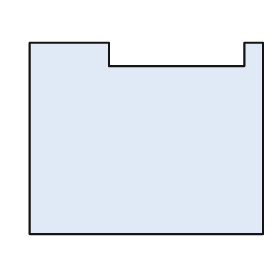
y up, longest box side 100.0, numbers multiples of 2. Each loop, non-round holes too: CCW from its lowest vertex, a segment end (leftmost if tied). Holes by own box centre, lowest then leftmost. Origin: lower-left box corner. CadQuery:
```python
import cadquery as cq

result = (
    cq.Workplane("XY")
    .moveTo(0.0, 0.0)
    .lineTo(100.0, 0.0)
    .lineTo(100.0, 82.0)
    .lineTo(92.0, 82.0)
    .lineTo(92.0, 72.0)
    .lineTo(34.0, 72.0)
    .lineTo(34.0, 82.0)
    .lineTo(0.0, 82.0)
    .close()
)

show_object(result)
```